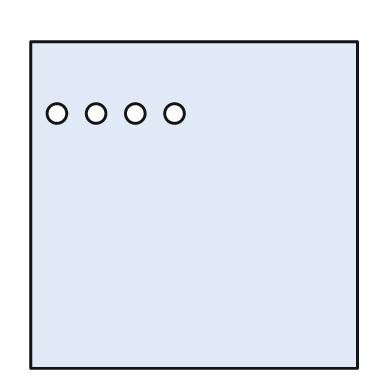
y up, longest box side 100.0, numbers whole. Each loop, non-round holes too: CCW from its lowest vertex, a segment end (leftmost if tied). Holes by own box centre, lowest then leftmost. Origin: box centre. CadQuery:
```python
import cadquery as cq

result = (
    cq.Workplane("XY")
    .moveTo(-50.0, -50.0)
    .lineTo(50.0, -50.0)
    .lineTo(50.0, 50.0)
    .lineTo(-50.0, 50.0)
    .close()
    .moveTo(-42.0, 28.0)
    .circle(3.0)
    .moveTo(-30.0, 28.0)
    .circle(3.0)
    .moveTo(-18.0, 28.0)
    .circle(3.0)
    .moveTo(-6.0, 28.0)
    .circle(3.0)
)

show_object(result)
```